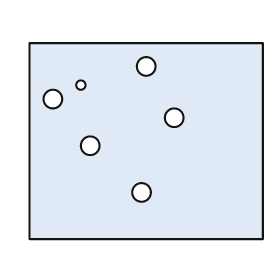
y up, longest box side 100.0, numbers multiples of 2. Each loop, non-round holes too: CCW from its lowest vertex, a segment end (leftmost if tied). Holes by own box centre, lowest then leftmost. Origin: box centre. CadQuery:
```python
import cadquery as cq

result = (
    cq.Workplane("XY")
    .moveTo(-50.0, -42.0)
    .lineTo(50.0, -42.0)
    .lineTo(50.0, 42.0)
    .lineTo(-50.0, 42.0)
    .close()
    .moveTo(-2.0, -22.0)
    .circle(4.0)
    .moveTo(-24.0, -2.0)
    .circle(4.0)
    .moveTo(12.0, 10.0)
    .circle(4.0)
    .moveTo(-40.0, 18.0)
    .circle(4.0)
    .moveTo(-28.0, 24.0)
    .circle(2.0)
    .moveTo(0.0, 32.0)
    .circle(4.0)
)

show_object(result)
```